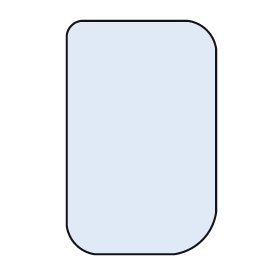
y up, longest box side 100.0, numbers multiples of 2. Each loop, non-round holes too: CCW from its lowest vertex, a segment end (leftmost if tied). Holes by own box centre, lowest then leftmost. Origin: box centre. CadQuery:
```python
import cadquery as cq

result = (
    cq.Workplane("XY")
    .moveTo(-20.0, -50.0)
    .lineTo(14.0, -50.0)
    .threePointArc((26.0, -44.0), (32.0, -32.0))
    .lineTo(32.0, 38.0)
    .threePointArc((28.0, 46.0), (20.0, 50.0))
    .lineTo(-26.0, 50.0)
    .threePointArc((-30.0, 48.0), (-32.0, 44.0))
    .lineTo(-32.0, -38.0)
    .threePointArc((-28.0, -46.0), (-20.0, -50.0))
    .close()
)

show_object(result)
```